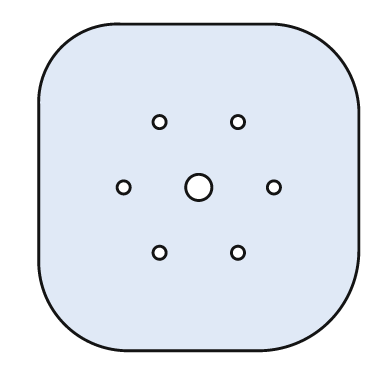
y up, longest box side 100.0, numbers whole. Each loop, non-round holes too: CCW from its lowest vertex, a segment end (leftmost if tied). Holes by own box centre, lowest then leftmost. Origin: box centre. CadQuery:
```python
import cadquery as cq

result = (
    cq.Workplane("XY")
    .moveTo(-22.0, -50.0)
    .lineTo(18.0, -50.0)
    .threePointArc((40.0, -41.0), (49.0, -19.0))
    .lineTo(49.0, 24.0)
    .threePointArc((41.0, 42.0), (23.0, 50.0))
    .lineTo(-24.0, 50.0)
    .threePointArc((-42.0, 43.0), (-49.0, 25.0))
    .lineTo(-49.0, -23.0)
    .threePointArc((-41.0, -42.0), (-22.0, -50.0))
    .close()
    .moveTo(-12.0, -20.0)
    .circle(2.0)
    .moveTo(12.0, -20.0)
    .circle(2.0)
    .moveTo(-23.0, 0.0)
    .circle(2.0)
    .moveTo(0.0, 0.0)
    .circle(4.0)
    .moveTo(23.0, 0.0)
    .circle(2.0)
    .moveTo(-12.0, 20.0)
    .circle(2.0)
    .moveTo(12.0, 20.0)
    .circle(2.0)
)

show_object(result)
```